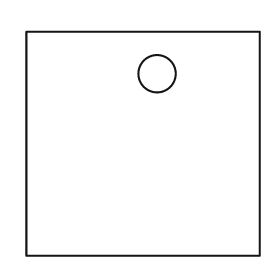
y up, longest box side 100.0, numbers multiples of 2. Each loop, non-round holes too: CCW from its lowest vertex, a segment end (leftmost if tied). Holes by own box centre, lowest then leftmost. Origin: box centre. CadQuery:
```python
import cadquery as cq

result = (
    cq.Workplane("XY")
    .moveTo(-50.0, -48.0)
    .lineTo(50.0, -48.0)
    .lineTo(50.0, 48.0)
    .lineTo(-50.0, 48.0)
    .close()
    .moveTo(6.0, 30.0)
    .circle(8.0)
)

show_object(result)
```